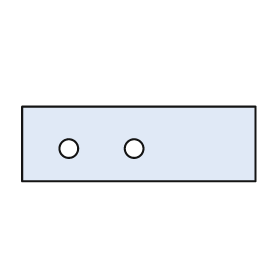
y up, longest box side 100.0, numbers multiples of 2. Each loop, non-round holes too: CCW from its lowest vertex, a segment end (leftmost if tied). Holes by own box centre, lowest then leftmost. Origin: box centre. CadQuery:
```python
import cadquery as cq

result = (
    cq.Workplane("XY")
    .moveTo(-50.0, -16.0)
    .lineTo(50.0, -16.0)
    .lineTo(50.0, 16.0)
    .lineTo(-50.0, 16.0)
    .close()
    .moveTo(-30.0, -2.0)
    .circle(4.0)
    .moveTo(-2.0, -2.0)
    .circle(4.0)
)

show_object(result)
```